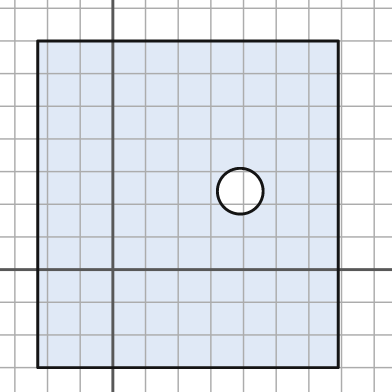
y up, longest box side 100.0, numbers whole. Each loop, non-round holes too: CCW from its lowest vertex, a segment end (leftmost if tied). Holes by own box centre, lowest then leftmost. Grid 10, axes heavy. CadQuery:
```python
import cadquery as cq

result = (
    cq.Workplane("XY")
    .moveTo(-23.0, -30.0)
    .lineTo(69.0, -30.0)
    .lineTo(69.0, 70.0)
    .lineTo(-23.0, 70.0)
    .close()
    .moveTo(39.0, 24.0)
    .circle(7.0)
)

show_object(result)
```